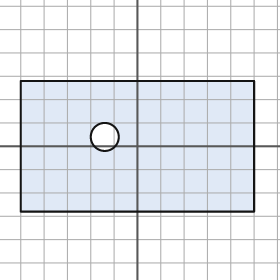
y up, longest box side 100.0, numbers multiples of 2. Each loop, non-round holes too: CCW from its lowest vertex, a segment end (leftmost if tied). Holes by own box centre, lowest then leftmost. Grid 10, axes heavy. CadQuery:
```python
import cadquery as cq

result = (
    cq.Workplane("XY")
    .moveTo(-50.0, -28.0)
    .lineTo(50.0, -28.0)
    .lineTo(50.0, 28.0)
    .lineTo(-50.0, 28.0)
    .close()
    .moveTo(-14.0, 4.0)
    .circle(6.0)
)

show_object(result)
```